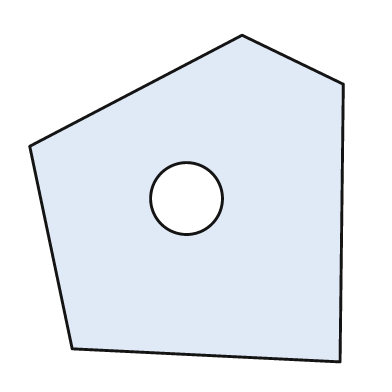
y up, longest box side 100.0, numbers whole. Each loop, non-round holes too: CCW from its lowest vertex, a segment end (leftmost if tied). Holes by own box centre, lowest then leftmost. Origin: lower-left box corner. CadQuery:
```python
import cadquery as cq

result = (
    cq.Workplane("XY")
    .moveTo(95.0, 0.0)
    .lineTo(96.0, 85.0)
    .lineTo(65.0, 100.0)
    .lineTo(0.0, 66.0)
    .lineTo(13.0, 4.0)
    .close()
    .moveTo(48.0, 50.0)
    .circle(11.0)
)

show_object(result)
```